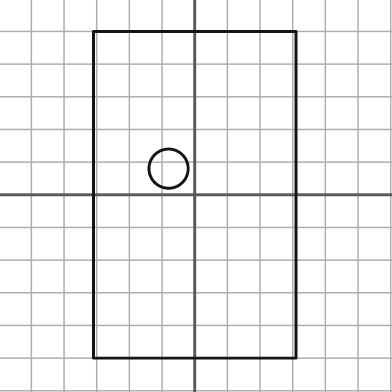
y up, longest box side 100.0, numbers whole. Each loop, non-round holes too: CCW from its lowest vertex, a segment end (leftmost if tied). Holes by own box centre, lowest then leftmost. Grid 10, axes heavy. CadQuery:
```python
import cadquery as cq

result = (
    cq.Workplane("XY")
    .moveTo(-31.0, -50.0)
    .lineTo(31.0, -50.0)
    .lineTo(31.0, 50.0)
    .lineTo(-31.0, 50.0)
    .close()
    .moveTo(-8.0, 8.0)
    .circle(6.0)
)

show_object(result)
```